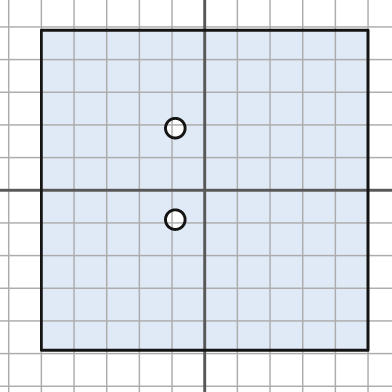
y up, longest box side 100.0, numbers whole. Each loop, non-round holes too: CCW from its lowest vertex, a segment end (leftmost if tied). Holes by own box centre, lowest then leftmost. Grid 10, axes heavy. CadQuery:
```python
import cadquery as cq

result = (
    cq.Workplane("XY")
    .moveTo(-50.0, -49.0)
    .lineTo(50.0, -49.0)
    .lineTo(50.0, 49.0)
    .lineTo(-50.0, 49.0)
    .close()
    .moveTo(-9.0, -9.0)
    .circle(3.0)
    .moveTo(-9.0, 19.0)
    .circle(3.0)
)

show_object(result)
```